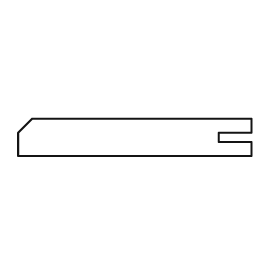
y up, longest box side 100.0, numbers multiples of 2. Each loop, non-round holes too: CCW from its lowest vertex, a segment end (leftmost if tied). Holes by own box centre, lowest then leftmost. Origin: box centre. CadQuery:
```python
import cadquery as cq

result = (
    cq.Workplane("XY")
    .moveTo(-50.0, -8.0)
    .lineTo(50.0, -8.0)
    .lineTo(50.0, -2.0)
    .lineTo(36.0, -2.0)
    .lineTo(36.0, 2.0)
    .lineTo(50.0, 2.0)
    .lineTo(50.0, 8.0)
    .lineTo(-44.0, 8.0)
    .lineTo(-50.0, 2.0)
    .close()
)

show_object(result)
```